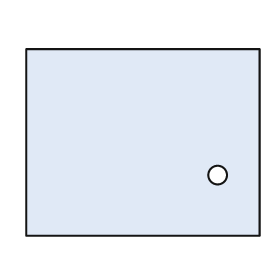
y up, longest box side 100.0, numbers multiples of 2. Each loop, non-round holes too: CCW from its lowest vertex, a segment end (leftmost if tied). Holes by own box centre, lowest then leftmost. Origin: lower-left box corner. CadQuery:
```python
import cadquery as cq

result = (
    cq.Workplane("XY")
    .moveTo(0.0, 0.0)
    .lineTo(100.0, 0.0)
    .lineTo(100.0, 80.0)
    .lineTo(0.0, 80.0)
    .close()
    .moveTo(82.0, 26.0)
    .circle(4.0)
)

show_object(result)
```